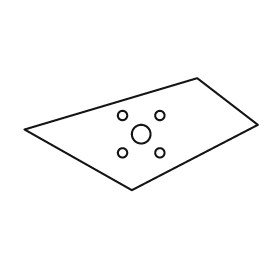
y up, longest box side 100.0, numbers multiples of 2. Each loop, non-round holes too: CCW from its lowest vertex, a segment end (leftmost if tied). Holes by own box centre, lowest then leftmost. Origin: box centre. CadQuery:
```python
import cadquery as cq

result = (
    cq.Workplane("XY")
    .moveTo(-4.0, -24.0)
    .lineTo(50.0, 4.0)
    .lineTo(24.0, 24.0)
    .lineTo(-50.0, 2.0)
    .close()
    .moveTo(-8.0, -8.0)
    .circle(2.0)
    .moveTo(8.0, -8.0)
    .circle(2.0)
    .moveTo(0.0, 0.0)
    .circle(4.0)
    .moveTo(-8.0, 8.0)
    .circle(2.0)
    .moveTo(8.0, 8.0)
    .circle(2.0)
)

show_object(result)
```